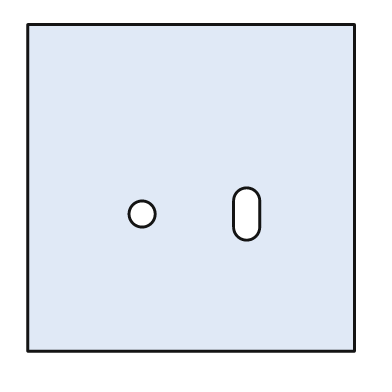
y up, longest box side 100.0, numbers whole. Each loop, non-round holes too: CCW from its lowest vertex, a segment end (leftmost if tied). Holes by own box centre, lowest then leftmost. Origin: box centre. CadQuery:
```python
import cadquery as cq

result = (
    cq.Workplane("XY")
    .moveTo(-50.0, -50.0)
    .lineTo(50.0, -50.0)
    .lineTo(50.0, 50.0)
    .lineTo(-50.0, 50.0)
    .close()
    .moveTo(-15.0, -8.0)
    .circle(4.0)
    .moveTo(13.0, -12.0)
    .threePointArc((17.0, -16.0), (21.0, -12.0))
    .lineTo(21.0, -4.0)
    .threePointArc((17.0, 0.0), (13.0, -4.0))
    .close()
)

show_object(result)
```